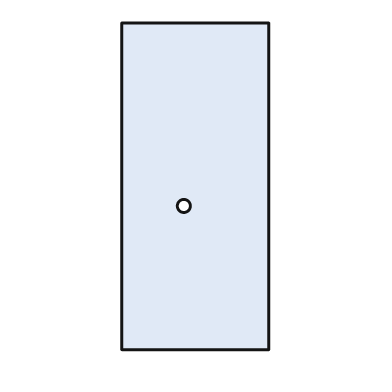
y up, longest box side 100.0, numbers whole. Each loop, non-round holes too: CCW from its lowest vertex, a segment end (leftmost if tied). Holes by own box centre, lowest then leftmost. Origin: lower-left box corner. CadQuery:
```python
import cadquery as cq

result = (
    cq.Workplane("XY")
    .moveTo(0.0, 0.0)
    .lineTo(45.0, 0.0)
    .lineTo(45.0, 100.0)
    .lineTo(0.0, 100.0)
    .close()
    .moveTo(19.0, 44.0)
    .circle(2.0)
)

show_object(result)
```